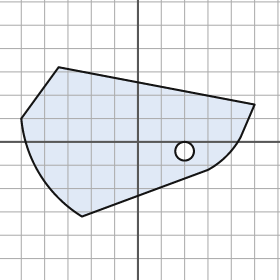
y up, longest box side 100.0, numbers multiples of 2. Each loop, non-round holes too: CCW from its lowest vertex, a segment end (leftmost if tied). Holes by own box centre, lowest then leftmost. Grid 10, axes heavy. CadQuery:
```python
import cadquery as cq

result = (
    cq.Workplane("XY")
    .moveTo(-24.0, -32.0)
    .lineTo(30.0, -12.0)
    .threePointArc((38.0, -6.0), (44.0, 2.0))
    .lineTo(50.0, 16.0)
    .lineTo(-34.0, 32.0)
    .lineTo(-50.0, 10.0)
    .threePointArc((-42.0, -14.0), (-24.0, -32.0))
    .close()
    .moveTo(20.0, -4.0)
    .circle(4.0)
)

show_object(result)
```